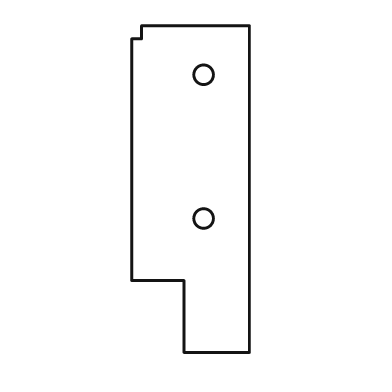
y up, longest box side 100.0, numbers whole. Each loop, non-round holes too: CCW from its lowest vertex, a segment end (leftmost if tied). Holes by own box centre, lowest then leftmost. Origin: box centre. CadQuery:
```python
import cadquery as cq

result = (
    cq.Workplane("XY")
    .moveTo(-2.0, -50.0)
    .lineTo(18.0, -50.0)
    .lineTo(18.0, 50.0)
    .lineTo(-15.0, 50.0)
    .lineTo(-15.0, 46.0)
    .lineTo(-18.0, 46.0)
    .lineTo(-18.0, -28.0)
    .lineTo(-2.0, -28.0)
    .close()
    .moveTo(4.0, -9.0)
    .circle(3.0)
    .moveTo(4.0, 35.0)
    .circle(3.0)
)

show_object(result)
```